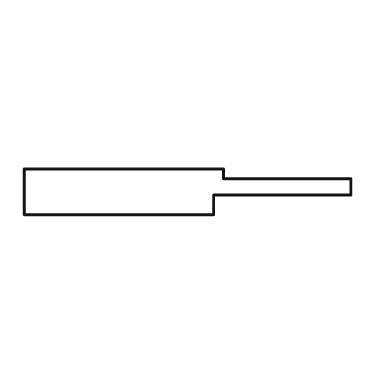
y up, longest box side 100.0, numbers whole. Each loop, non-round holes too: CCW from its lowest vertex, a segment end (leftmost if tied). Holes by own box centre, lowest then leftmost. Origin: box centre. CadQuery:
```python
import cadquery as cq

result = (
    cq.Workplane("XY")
    .moveTo(-50.0, -7.0)
    .lineTo(8.0, -7.0)
    .lineTo(8.0, -1.0)
    .lineTo(50.0, -1.0)
    .lineTo(50.0, 4.0)
    .lineTo(11.0, 4.0)
    .lineTo(11.0, 7.0)
    .lineTo(-50.0, 7.0)
    .close()
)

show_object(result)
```